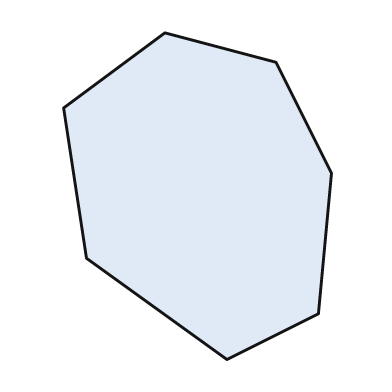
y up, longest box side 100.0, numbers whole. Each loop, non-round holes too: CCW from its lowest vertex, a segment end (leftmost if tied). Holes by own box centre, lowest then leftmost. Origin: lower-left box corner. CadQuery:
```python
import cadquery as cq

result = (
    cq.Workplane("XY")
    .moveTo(50.0, 0.0)
    .lineTo(78.0, 14.0)
    .lineTo(82.0, 57.0)
    .lineTo(65.0, 91.0)
    .lineTo(31.0, 100.0)
    .lineTo(0.0, 77.0)
    .lineTo(7.0, 31.0)
    .close()
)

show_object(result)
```